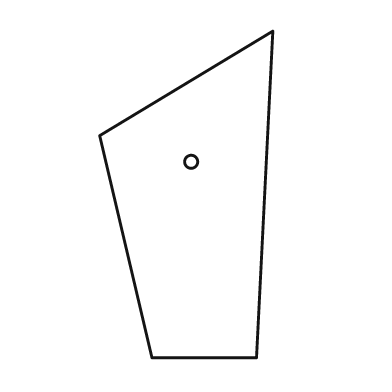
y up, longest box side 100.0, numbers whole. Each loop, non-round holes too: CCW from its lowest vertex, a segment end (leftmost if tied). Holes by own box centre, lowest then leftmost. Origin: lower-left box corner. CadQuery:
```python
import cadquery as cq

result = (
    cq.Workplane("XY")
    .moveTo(16.0, 0.0)
    .lineTo(48.0, 0.0)
    .lineTo(53.0, 100.0)
    .lineTo(0.0, 68.0)
    .close()
    .moveTo(28.0, 60.0)
    .circle(2.0)
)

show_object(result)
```